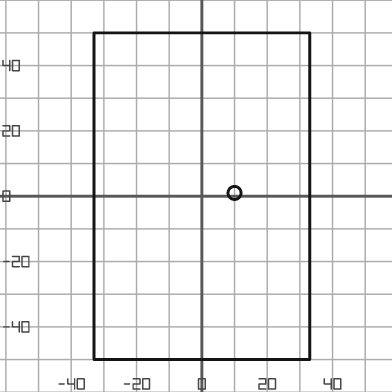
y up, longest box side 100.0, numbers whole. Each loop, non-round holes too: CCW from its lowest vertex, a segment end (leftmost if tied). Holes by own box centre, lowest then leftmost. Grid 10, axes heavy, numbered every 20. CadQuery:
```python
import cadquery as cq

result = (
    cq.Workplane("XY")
    .moveTo(-33.0, -50.0)
    .lineTo(33.0, -50.0)
    .lineTo(33.0, 50.0)
    .lineTo(-33.0, 50.0)
    .close()
    .moveTo(10.0, 1.0)
    .circle(2.0)
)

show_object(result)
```